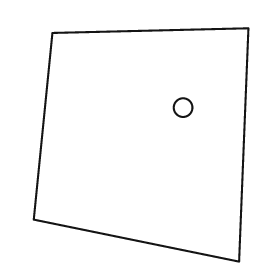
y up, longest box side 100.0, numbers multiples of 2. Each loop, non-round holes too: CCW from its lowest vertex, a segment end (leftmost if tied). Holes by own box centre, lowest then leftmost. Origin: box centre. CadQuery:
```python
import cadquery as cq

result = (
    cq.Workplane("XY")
    .moveTo(42.0, -50.0)
    .lineTo(46.0, 50.0)
    .lineTo(-38.0, 48.0)
    .lineTo(-46.0, -32.0)
    .close()
    .moveTo(18.0, 16.0)
    .circle(4.0)
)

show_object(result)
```